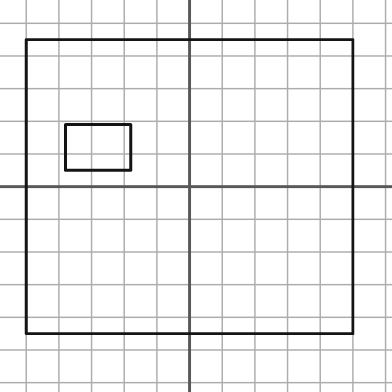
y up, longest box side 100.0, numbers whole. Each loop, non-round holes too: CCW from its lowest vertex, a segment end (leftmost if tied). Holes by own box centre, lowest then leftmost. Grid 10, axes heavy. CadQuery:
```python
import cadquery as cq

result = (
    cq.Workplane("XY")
    .moveTo(-50.0, -45.0)
    .lineTo(50.0, -45.0)
    .lineTo(50.0, 45.0)
    .lineTo(-50.0, 45.0)
    .close()
    .moveTo(-38.0, 5.0)
    .lineTo(-18.0, 5.0)
    .lineTo(-18.0, 19.0)
    .lineTo(-38.0, 19.0)
    .close()
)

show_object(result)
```